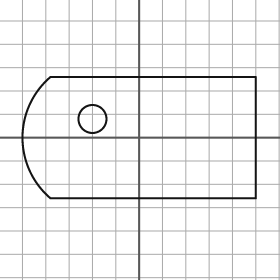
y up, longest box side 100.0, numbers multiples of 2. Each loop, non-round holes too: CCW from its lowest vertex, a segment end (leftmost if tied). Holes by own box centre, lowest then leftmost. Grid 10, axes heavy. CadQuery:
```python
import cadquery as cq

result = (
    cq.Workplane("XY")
    .moveTo(-38.0, -26.0)
    .lineTo(50.0, -26.0)
    .lineTo(50.0, 26.0)
    .lineTo(-38.0, 26.0)
    .threePointArc((-50.0, 0.0), (-38.0, -26.0))
    .close()
    .moveTo(-20.0, 8.0)
    .circle(6.0)
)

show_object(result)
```